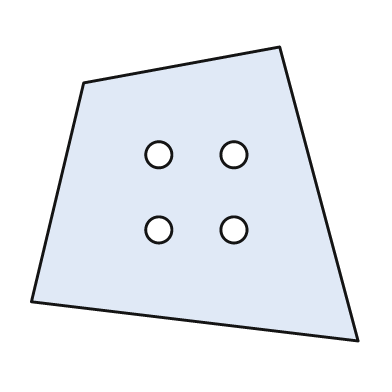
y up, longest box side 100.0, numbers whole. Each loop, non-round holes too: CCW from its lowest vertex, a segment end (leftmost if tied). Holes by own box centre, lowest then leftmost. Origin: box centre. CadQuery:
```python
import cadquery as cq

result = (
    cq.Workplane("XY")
    .moveTo(50.0, -45.0)
    .lineTo(26.0, 45.0)
    .lineTo(-34.0, 34.0)
    .lineTo(-50.0, -33.0)
    .close()
    .moveTo(-11.0, -11.0)
    .circle(4.0)
    .moveTo(12.0, -11.0)
    .circle(4.0)
    .moveTo(-11.0, 12.0)
    .circle(4.0)
    .moveTo(12.0, 12.0)
    .circle(4.0)
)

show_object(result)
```